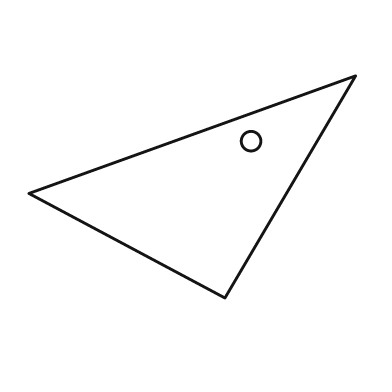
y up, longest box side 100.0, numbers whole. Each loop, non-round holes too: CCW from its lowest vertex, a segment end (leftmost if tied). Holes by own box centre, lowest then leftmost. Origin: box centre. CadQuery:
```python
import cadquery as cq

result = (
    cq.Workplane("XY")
    .moveTo(10.0, -34.0)
    .lineTo(50.0, 34.0)
    .lineTo(-50.0, -2.0)
    .close()
    .moveTo(18.0, 14.0)
    .circle(3.0)
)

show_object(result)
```